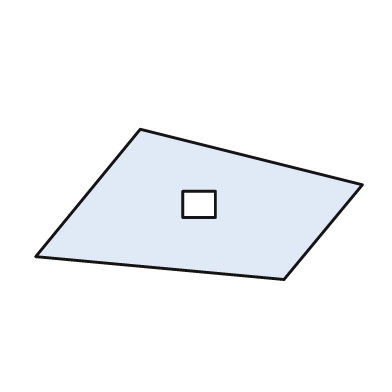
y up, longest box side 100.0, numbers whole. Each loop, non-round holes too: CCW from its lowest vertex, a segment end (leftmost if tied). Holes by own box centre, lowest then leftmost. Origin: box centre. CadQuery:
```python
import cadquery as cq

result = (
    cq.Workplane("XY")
    .moveTo(26.0, -23.0)
    .lineTo(50.0, 6.0)
    .lineTo(-18.0, 23.0)
    .lineTo(-50.0, -16.0)
    .close()
    .moveTo(-5.0, -4.0)
    .lineTo(5.0, -4.0)
    .lineTo(5.0, 4.0)
    .lineTo(-5.0, 4.0)
    .close()
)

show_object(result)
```